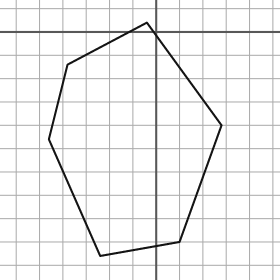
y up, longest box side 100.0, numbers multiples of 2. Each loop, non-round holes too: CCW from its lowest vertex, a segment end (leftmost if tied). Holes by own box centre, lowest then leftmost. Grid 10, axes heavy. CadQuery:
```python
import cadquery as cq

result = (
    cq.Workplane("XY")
    .moveTo(-24.0, -96.0)
    .lineTo(10.0, -90.0)
    .lineTo(28.0, -40.0)
    .lineTo(-4.0, 4.0)
    .lineTo(-38.0, -14.0)
    .lineTo(-46.0, -46.0)
    .close()
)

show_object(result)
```